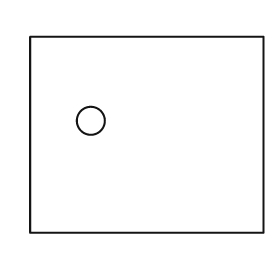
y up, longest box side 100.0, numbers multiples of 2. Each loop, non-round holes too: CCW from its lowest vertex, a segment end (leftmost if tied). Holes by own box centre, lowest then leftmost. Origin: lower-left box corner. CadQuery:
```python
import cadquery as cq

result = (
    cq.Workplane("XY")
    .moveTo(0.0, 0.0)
    .lineTo(100.0, 0.0)
    .lineTo(100.0, 84.0)
    .lineTo(0.0, 84.0)
    .close()
    .moveTo(26.0, 48.0)
    .circle(6.0)
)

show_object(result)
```